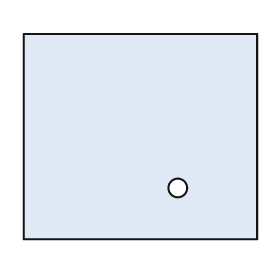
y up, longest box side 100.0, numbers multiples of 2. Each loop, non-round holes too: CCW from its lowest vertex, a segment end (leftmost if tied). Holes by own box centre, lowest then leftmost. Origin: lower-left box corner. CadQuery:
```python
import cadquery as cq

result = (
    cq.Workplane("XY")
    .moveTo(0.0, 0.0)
    .lineTo(100.0, 0.0)
    .lineTo(100.0, 88.0)
    .lineTo(0.0, 88.0)
    .close()
    .moveTo(66.0, 22.0)
    .circle(4.0)
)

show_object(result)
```